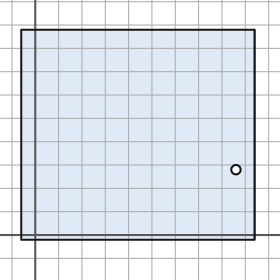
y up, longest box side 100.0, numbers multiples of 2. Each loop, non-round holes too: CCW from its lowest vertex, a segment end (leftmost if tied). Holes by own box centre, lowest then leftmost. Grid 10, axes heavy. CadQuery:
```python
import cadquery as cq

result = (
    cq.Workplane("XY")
    .moveTo(-6.0, -2.0)
    .lineTo(94.0, -2.0)
    .lineTo(94.0, 88.0)
    .lineTo(-6.0, 88.0)
    .close()
    .moveTo(86.0, 28.0)
    .circle(2.0)
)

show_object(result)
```